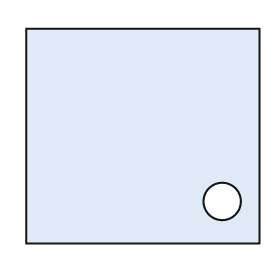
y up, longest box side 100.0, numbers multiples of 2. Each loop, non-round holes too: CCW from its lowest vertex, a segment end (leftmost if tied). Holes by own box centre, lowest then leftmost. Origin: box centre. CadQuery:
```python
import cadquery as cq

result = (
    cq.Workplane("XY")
    .moveTo(-50.0, -46.0)
    .lineTo(50.0, -46.0)
    .lineTo(50.0, 46.0)
    .lineTo(-50.0, 46.0)
    .close()
    .moveTo(34.0, -28.0)
    .circle(8.0)
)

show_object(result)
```